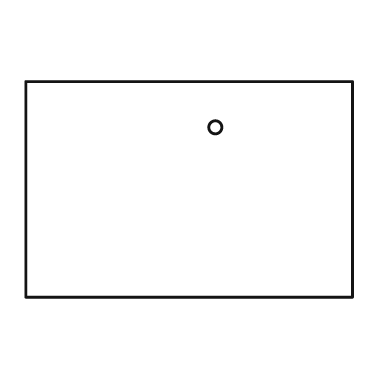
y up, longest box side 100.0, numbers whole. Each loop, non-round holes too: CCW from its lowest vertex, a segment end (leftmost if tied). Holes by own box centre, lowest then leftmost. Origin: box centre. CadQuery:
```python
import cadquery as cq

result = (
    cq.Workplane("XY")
    .moveTo(-50.0, -33.0)
    .lineTo(50.0, -33.0)
    .lineTo(50.0, 33.0)
    .lineTo(-50.0, 33.0)
    .close()
    .moveTo(8.0, 19.0)
    .circle(2.0)
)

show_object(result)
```